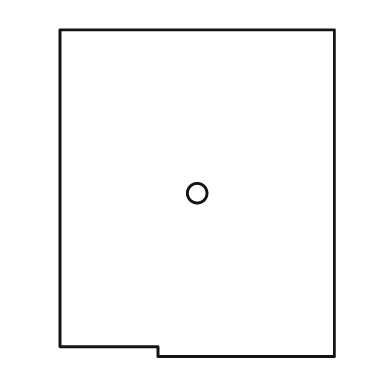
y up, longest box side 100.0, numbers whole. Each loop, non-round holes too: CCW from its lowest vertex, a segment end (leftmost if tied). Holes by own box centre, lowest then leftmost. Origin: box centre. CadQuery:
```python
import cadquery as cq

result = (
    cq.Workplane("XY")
    .moveTo(-12.0, -50.0)
    .lineTo(42.0, -50.0)
    .lineTo(42.0, 50.0)
    .lineTo(-42.0, 50.0)
    .lineTo(-42.0, -47.0)
    .lineTo(-12.0, -47.0)
    .close()
    .moveTo(0.0, 0.0)
    .circle(3.0)
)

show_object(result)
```